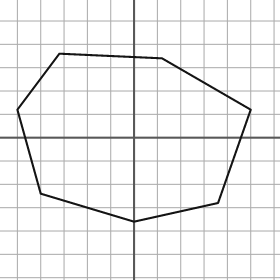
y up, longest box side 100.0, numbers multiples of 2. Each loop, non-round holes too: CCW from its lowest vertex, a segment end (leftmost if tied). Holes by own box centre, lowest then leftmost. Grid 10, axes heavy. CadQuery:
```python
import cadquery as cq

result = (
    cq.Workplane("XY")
    .moveTo(0.0, -36.0)
    .lineTo(36.0, -28.0)
    .lineTo(50.0, 12.0)
    .lineTo(12.0, 34.0)
    .lineTo(-32.0, 36.0)
    .lineTo(-50.0, 12.0)
    .lineTo(-40.0, -24.0)
    .close()
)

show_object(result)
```